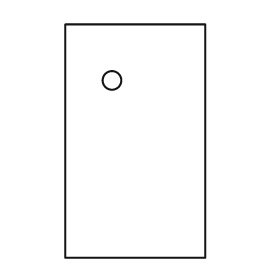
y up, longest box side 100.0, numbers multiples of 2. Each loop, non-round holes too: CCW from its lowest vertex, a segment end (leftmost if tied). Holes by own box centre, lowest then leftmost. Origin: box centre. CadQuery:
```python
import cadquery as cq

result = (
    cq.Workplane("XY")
    .moveTo(-30.0, -50.0)
    .lineTo(30.0, -50.0)
    .lineTo(30.0, 50.0)
    .lineTo(-30.0, 50.0)
    .close()
    .moveTo(-10.0, 26.0)
    .circle(4.0)
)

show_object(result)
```